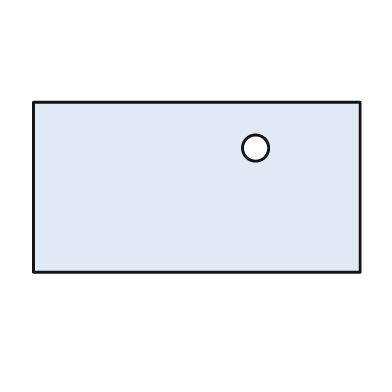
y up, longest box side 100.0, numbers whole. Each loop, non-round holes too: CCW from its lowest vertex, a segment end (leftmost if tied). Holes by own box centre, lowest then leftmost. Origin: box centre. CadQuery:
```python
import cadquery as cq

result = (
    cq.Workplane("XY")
    .moveTo(-50.0, -26.0)
    .lineTo(50.0, -26.0)
    .lineTo(50.0, 26.0)
    .lineTo(-50.0, 26.0)
    .close()
    .moveTo(18.0, 12.0)
    .circle(4.0)
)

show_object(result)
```